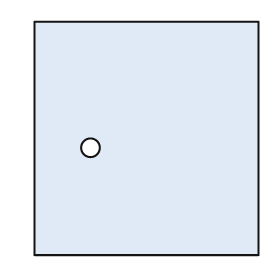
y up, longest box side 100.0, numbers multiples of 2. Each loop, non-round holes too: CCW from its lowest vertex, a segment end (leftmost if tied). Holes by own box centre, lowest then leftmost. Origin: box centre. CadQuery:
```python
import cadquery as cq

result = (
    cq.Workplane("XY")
    .moveTo(-48.0, -50.0)
    .lineTo(48.0, -50.0)
    .lineTo(48.0, 50.0)
    .lineTo(-48.0, 50.0)
    .close()
    .moveTo(-24.0, -4.0)
    .circle(4.0)
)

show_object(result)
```